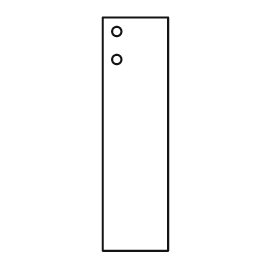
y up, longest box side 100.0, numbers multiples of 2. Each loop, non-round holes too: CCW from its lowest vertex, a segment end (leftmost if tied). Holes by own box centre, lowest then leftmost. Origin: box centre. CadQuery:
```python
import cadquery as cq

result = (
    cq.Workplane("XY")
    .moveTo(-14.0, -50.0)
    .lineTo(14.0, -50.0)
    .lineTo(14.0, 50.0)
    .lineTo(-14.0, 50.0)
    .close()
    .moveTo(-8.0, 32.0)
    .circle(2.0)
    .moveTo(-8.0, 44.0)
    .circle(2.0)
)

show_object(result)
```